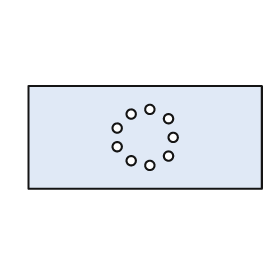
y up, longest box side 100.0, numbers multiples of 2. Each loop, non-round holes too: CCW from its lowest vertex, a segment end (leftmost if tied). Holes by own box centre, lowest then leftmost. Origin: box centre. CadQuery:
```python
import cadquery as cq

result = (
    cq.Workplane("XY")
    .moveTo(-50.0, -22.0)
    .lineTo(50.0, -22.0)
    .lineTo(50.0, 22.0)
    .lineTo(-50.0, 22.0)
    .close()
    .moveTo(2.0, -12.0)
    .circle(2.0)
    .moveTo(-6.0, -10.0)
    .circle(2.0)
    .moveTo(10.0, -8.0)
    .circle(2.0)
    .moveTo(-12.0, -4.0)
    .circle(2.0)
    .moveTo(12.0, 0.0)
    .circle(2.0)
    .moveTo(-12.0, 4.0)
    .circle(2.0)
    .moveTo(10.0, 8.0)
    .circle(2.0)
    .moveTo(-6.0, 10.0)
    .circle(2.0)
    .moveTo(2.0, 12.0)
    .circle(2.0)
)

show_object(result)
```